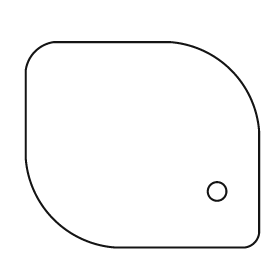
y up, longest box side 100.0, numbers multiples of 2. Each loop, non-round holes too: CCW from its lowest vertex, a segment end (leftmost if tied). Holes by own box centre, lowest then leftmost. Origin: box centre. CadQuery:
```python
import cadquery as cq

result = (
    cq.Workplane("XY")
    .moveTo(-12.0, -44.0)
    .lineTo(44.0, -44.0)
    .threePointArc((48.0, -42.0), (50.0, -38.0))
    .lineTo(50.0, 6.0)
    .threePointArc((38.0, 32.0), (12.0, 44.0))
    .lineTo(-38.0, 44.0)
    .threePointArc((-46.0, 40.0), (-50.0, 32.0))
    .lineTo(-50.0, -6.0)
    .threePointArc((-38.0, -32.0), (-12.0, -44.0))
    .close()
    .moveTo(32.0, -20.0)
    .circle(4.0)
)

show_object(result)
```